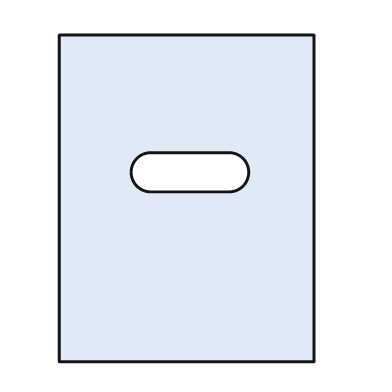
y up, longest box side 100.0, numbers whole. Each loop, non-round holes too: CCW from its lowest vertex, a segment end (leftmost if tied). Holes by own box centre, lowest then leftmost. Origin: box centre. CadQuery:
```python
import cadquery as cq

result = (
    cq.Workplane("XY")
    .moveTo(-39.0, -50.0)
    .lineTo(39.0, -50.0)
    .lineTo(39.0, 50.0)
    .lineTo(-39.0, 50.0)
    .close()
    .moveTo(-11.0, 2.0)
    .lineTo(13.0, 2.0)
    .threePointArc((19.0, 8.0), (13.0, 14.0))
    .lineTo(-11.0, 14.0)
    .threePointArc((-17.0, 8.0), (-11.0, 2.0))
    .close()
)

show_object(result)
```